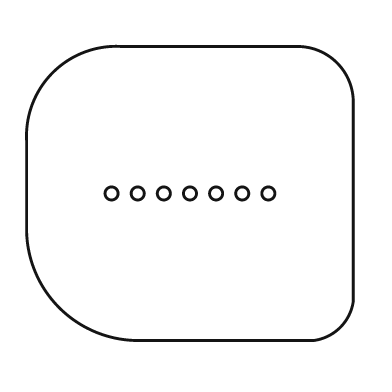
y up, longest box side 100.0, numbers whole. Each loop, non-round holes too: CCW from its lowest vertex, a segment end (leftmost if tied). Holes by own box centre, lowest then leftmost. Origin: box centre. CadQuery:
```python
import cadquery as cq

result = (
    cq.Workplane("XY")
    .moveTo(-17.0, -45.0)
    .lineTo(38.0, -45.0)
    .threePointArc((46.0, -41.0), (50.0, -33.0))
    .lineTo(50.0, 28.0)
    .threePointArc((45.0, 40.0), (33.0, 45.0))
    .lineTo(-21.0, 45.0)
    .threePointArc((-42.0, 37.0), (-50.0, 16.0))
    .lineTo(-50.0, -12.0)
    .threePointArc((-40.0, -35.0), (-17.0, -45.0))
    .close()
    .moveTo(-24.0, 0.0)
    .circle(2.0)
    .moveTo(-16.0, 0.0)
    .circle(2.0)
    .moveTo(-8.0, 0.0)
    .circle(2.0)
    .moveTo(0.0, 0.0)
    .circle(2.0)
    .moveTo(8.0, 0.0)
    .circle(2.0)
    .moveTo(16.0, 0.0)
    .circle(2.0)
    .moveTo(24.0, 0.0)
    .circle(2.0)
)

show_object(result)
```